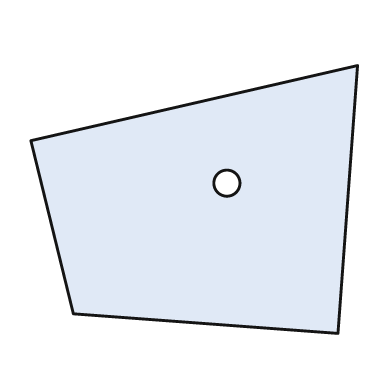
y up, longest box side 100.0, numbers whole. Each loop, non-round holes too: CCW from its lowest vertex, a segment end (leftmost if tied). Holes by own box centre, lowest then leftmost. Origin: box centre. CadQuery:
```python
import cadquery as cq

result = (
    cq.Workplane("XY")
    .moveTo(44.0, -41.0)
    .lineTo(50.0, 41.0)
    .lineTo(-50.0, 18.0)
    .lineTo(-37.0, -35.0)
    .close()
    .moveTo(10.0, 5.0)
    .circle(4.0)
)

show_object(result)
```